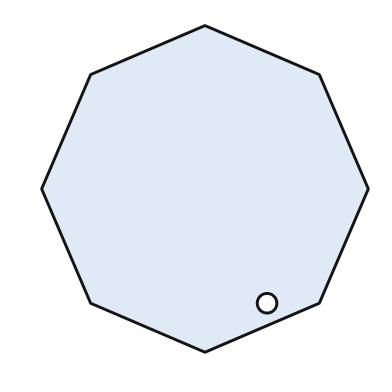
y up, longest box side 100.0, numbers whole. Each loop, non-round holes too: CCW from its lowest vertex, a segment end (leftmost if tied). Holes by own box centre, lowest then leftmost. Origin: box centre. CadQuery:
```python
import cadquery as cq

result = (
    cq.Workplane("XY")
    .moveTo(0.0, -50.0)
    .lineTo(35.0, -35.0)
    .lineTo(50.0, 0.0)
    .lineTo(35.0, 35.0)
    .lineTo(0.0, 50.0)
    .lineTo(-35.0, 35.0)
    .lineTo(-50.0, 0.0)
    .lineTo(-35.0, -35.0)
    .close()
    .moveTo(19.0, -35.0)
    .circle(3.0)
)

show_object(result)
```